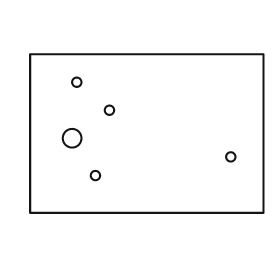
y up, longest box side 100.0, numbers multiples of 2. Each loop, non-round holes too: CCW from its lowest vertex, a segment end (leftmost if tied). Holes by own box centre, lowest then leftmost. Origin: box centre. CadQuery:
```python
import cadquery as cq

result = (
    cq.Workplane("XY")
    .moveTo(-50.0, -34.0)
    .lineTo(50.0, -34.0)
    .lineTo(50.0, 34.0)
    .lineTo(-50.0, 34.0)
    .close()
    .moveTo(-22.0, -18.0)
    .circle(2.0)
    .moveTo(36.0, -10.0)
    .circle(2.0)
    .moveTo(-32.0, -2.0)
    .circle(4.0)
    .moveTo(-16.0, 10.0)
    .circle(2.0)
    .moveTo(-30.0, 22.0)
    .circle(2.0)
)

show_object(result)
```